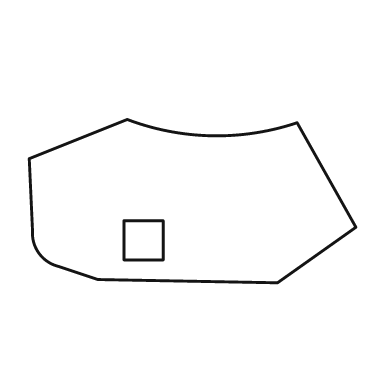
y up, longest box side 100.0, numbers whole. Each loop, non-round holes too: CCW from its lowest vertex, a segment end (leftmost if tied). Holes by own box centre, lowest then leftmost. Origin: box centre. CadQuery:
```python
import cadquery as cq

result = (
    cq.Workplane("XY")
    .moveTo(26.0, -25.0)
    .lineTo(50.0, -8.0)
    .lineTo(32.0, 24.0)
    .threePointArc((6.0, 20.0), (-20.0, 25.0))
    .lineTo(-50.0, 13.0)
    .lineTo(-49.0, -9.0)
    .threePointArc((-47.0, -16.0), (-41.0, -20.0))
    .lineTo(-29.0, -24.0)
    .close()
    .moveTo(-21.0, -18.0)
    .lineTo(-9.0, -18.0)
    .lineTo(-9.0, -6.0)
    .lineTo(-21.0, -6.0)
    .close()
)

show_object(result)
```